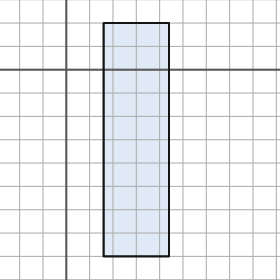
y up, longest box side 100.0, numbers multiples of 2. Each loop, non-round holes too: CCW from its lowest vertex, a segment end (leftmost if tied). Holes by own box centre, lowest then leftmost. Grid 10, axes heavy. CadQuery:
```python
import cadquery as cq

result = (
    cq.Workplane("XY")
    .moveTo(16.0, -80.0)
    .lineTo(44.0, -80.0)
    .lineTo(44.0, 20.0)
    .lineTo(16.0, 20.0)
    .close()
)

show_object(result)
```